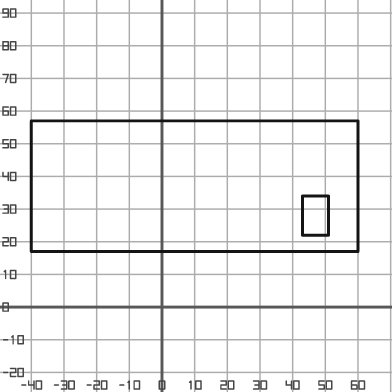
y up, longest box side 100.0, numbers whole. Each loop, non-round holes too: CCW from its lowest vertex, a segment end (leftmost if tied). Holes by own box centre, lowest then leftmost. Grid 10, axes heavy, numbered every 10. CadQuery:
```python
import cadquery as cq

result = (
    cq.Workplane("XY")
    .moveTo(-40.0, 17.0)
    .lineTo(60.0, 17.0)
    .lineTo(60.0, 57.0)
    .lineTo(-40.0, 57.0)
    .close()
    .moveTo(43.0, 22.0)
    .lineTo(51.0, 22.0)
    .lineTo(51.0, 34.0)
    .lineTo(43.0, 34.0)
    .close()
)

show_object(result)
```